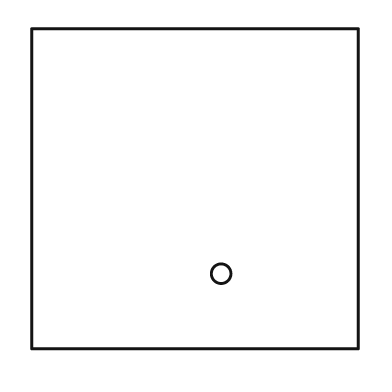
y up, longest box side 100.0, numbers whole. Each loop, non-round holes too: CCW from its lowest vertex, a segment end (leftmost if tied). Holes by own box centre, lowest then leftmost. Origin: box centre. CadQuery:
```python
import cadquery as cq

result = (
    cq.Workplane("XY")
    .moveTo(-50.0, -49.0)
    .lineTo(50.0, -49.0)
    .lineTo(50.0, 49.0)
    .lineTo(-50.0, 49.0)
    .close()
    .moveTo(8.0, -26.0)
    .circle(3.0)
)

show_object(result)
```